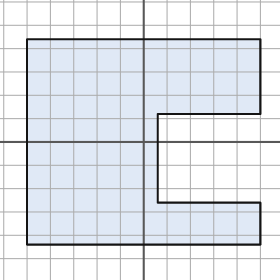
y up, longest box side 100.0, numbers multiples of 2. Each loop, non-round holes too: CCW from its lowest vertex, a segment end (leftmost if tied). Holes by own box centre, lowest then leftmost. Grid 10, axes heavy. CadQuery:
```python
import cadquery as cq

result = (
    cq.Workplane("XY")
    .moveTo(-50.0, -44.0)
    .lineTo(50.0, -44.0)
    .lineTo(50.0, -26.0)
    .lineTo(6.0, -26.0)
    .lineTo(6.0, 12.0)
    .lineTo(50.0, 12.0)
    .lineTo(50.0, 44.0)
    .lineTo(-50.0, 44.0)
    .close()
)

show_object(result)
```